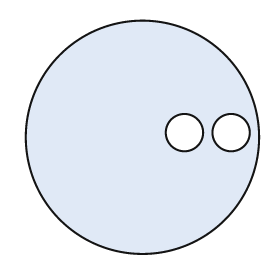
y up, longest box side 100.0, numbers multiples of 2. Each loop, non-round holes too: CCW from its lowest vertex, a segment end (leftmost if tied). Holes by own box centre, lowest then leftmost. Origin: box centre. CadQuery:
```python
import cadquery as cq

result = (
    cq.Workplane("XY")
    .moveTo(0.0, 0.0)
    .circle(50.0)
    .moveTo(18.0, 2.0)
    .circle(8.0)
    .moveTo(38.0, 2.0)
    .circle(8.0)
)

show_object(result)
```